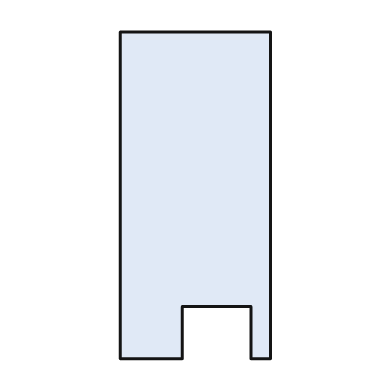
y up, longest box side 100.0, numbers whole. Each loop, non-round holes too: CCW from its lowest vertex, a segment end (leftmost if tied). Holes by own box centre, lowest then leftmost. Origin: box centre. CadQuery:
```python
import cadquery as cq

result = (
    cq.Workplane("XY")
    .moveTo(-23.0, -50.0)
    .lineTo(-4.0, -50.0)
    .lineTo(-4.0, -34.0)
    .lineTo(17.0, -34.0)
    .lineTo(17.0, -50.0)
    .lineTo(23.0, -50.0)
    .lineTo(23.0, 50.0)
    .lineTo(-23.0, 50.0)
    .close()
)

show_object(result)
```